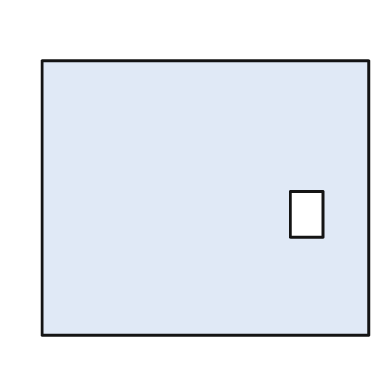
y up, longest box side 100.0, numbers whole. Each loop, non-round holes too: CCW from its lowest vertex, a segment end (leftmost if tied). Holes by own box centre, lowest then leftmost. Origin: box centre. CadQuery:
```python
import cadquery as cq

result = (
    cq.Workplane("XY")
    .moveTo(-50.0, -42.0)
    .lineTo(50.0, -42.0)
    .lineTo(50.0, 42.0)
    .lineTo(-50.0, 42.0)
    .close()
    .moveTo(26.0, -12.0)
    .lineTo(36.0, -12.0)
    .lineTo(36.0, 2.0)
    .lineTo(26.0, 2.0)
    .close()
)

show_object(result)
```